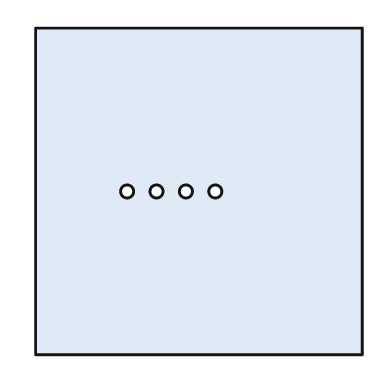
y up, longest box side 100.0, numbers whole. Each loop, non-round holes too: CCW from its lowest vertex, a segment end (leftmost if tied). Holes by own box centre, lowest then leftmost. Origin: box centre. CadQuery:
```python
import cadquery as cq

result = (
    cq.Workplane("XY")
    .moveTo(-50.0, -50.0)
    .lineTo(50.0, -50.0)
    .lineTo(50.0, 50.0)
    .lineTo(-50.0, 50.0)
    .close()
    .moveTo(-22.0, 0.0)
    .circle(2.0)
    .moveTo(-13.0, 0.0)
    .circle(2.0)
    .moveTo(-4.0, 0.0)
    .circle(2.0)
    .moveTo(5.0, 0.0)
    .circle(2.0)
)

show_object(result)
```